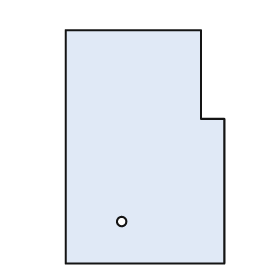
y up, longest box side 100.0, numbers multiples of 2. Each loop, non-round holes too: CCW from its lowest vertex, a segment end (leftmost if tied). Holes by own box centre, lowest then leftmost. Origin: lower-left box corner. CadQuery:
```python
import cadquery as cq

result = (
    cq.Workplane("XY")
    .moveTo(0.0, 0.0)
    .lineTo(68.0, 0.0)
    .lineTo(68.0, 62.0)
    .lineTo(58.0, 62.0)
    .lineTo(58.0, 100.0)
    .lineTo(0.0, 100.0)
    .close()
    .moveTo(24.0, 18.0)
    .circle(2.0)
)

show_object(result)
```